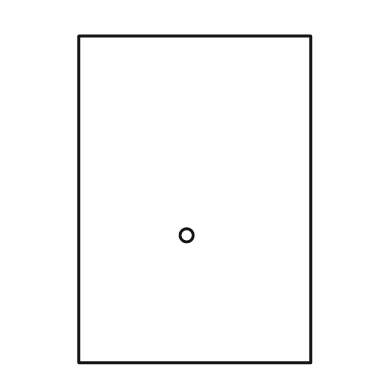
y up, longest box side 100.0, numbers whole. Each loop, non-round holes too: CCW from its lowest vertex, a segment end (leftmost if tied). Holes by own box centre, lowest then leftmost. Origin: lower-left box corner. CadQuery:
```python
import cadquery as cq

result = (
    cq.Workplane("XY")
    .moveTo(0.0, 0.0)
    .lineTo(71.0, 0.0)
    .lineTo(71.0, 100.0)
    .lineTo(0.0, 100.0)
    .close()
    .moveTo(33.0, 39.0)
    .circle(2.0)
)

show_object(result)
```